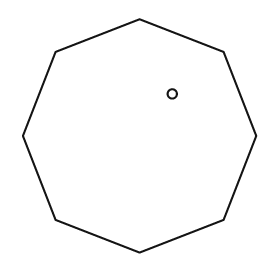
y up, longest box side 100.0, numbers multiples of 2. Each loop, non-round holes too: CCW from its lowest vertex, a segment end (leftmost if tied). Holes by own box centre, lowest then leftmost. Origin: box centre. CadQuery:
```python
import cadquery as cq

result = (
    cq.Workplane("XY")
    .moveTo(0.0, -50.0)
    .lineTo(36.0, -36.0)
    .lineTo(50.0, 0.0)
    .lineTo(36.0, 36.0)
    .lineTo(0.0, 50.0)
    .lineTo(-36.0, 36.0)
    .lineTo(-50.0, 0.0)
    .lineTo(-36.0, -36.0)
    .close()
    .moveTo(14.0, 18.0)
    .circle(2.0)
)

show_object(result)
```